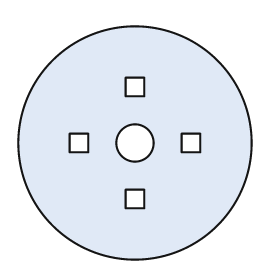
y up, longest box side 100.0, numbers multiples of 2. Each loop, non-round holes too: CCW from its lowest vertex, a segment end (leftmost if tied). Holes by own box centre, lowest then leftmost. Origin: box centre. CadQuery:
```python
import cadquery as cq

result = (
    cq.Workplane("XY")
    .moveTo(0.0, 0.0)
    .circle(50.0)
    .moveTo(-4.0, -28.0)
    .lineTo(4.0, -28.0)
    .lineTo(4.0, -20.0)
    .lineTo(-4.0, -20.0)
    .close()
    .moveTo(-28.0, -4.0)
    .lineTo(-20.0, -4.0)
    .lineTo(-20.0, 4.0)
    .lineTo(-28.0, 4.0)
    .close()
    .moveTo(0.0, 0.0)
    .circle(8.0)
    .moveTo(20.0, -4.0)
    .lineTo(28.0, -4.0)
    .lineTo(28.0, 4.0)
    .lineTo(20.0, 4.0)
    .close()
    .moveTo(-4.0, 20.0)
    .lineTo(4.0, 20.0)
    .lineTo(4.0, 28.0)
    .lineTo(-4.0, 28.0)
    .close()
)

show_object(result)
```